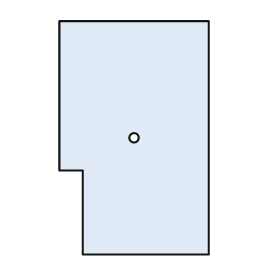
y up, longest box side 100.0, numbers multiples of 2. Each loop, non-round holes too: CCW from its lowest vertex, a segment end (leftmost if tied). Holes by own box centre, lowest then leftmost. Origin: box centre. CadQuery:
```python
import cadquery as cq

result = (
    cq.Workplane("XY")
    .moveTo(-22.0, -50.0)
    .lineTo(32.0, -50.0)
    .lineTo(32.0, 50.0)
    .lineTo(-32.0, 50.0)
    .lineTo(-32.0, -14.0)
    .lineTo(-22.0, -14.0)
    .close()
    .moveTo(0.0, 0.0)
    .circle(2.0)
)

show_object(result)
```